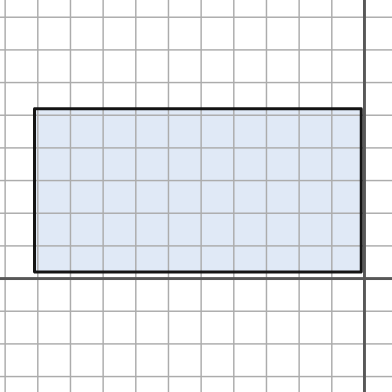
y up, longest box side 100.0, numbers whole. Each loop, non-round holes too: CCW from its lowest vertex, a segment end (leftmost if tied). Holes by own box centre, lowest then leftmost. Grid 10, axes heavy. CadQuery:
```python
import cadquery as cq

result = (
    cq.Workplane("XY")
    .moveTo(-101.0, 2.0)
    .lineTo(-1.0, 2.0)
    .lineTo(-1.0, 52.0)
    .lineTo(-101.0, 52.0)
    .close()
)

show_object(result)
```